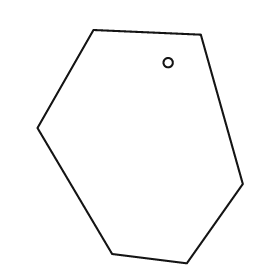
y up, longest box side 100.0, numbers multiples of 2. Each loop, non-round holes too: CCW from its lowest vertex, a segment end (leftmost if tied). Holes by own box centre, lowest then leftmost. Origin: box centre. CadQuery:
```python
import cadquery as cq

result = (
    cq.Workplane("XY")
    .moveTo(20.0, -50.0)
    .lineTo(44.0, -16.0)
    .lineTo(26.0, 48.0)
    .lineTo(-20.0, 50.0)
    .lineTo(-44.0, 8.0)
    .lineTo(-12.0, -46.0)
    .close()
    .moveTo(12.0, 36.0)
    .circle(2.0)
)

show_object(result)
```